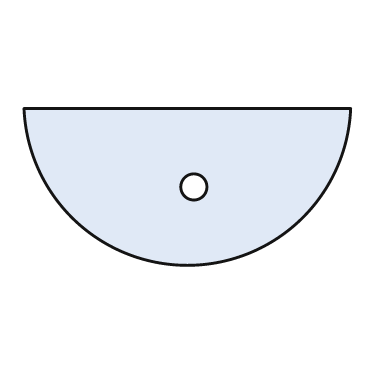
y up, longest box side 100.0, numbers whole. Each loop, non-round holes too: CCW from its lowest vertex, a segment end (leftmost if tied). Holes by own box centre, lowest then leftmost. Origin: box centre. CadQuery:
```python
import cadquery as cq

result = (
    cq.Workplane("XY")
    .moveTo(-50.0, 24.0)
    .threePointArc((0.0, -24.0), (50.0, 24.0))
    .close()
    .moveTo(2.0, 0.0)
    .circle(4.0)
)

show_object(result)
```